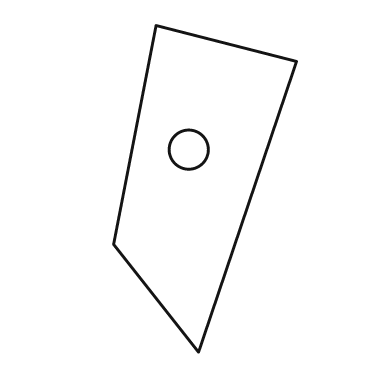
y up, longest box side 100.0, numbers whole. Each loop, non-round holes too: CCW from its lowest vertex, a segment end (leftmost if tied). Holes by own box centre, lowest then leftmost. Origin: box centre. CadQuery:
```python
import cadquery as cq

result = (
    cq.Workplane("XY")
    .moveTo(-2.0, -50.0)
    .lineTo(28.0, 39.0)
    .lineTo(-15.0, 50.0)
    .lineTo(-28.0, -17.0)
    .close()
    .moveTo(-5.0, 12.0)
    .circle(6.0)
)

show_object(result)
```